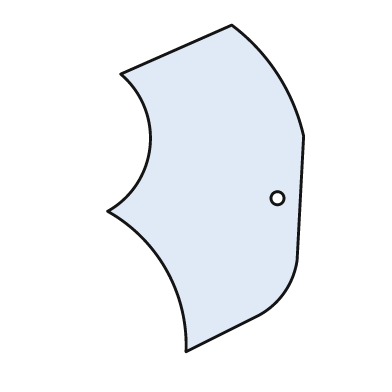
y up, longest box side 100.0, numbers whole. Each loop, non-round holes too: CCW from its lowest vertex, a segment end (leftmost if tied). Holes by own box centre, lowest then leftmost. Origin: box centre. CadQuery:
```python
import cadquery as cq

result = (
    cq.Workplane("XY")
    .moveTo(-6.0, -50.0)
    .lineTo(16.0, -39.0)
    .threePointArc((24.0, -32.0), (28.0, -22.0))
    .lineTo(30.0, 16.0)
    .threePointArc((22.0, 35.0), (8.0, 50.0))
    .lineTo(-26.0, 35.0)
    .threePointArc((-17.0, 13.0), (-30.0, -7.0))
    .threePointArc((-12.0, -25.0), (-6.0, -50.0))
    .close()
    .moveTo(22.0, -3.0)
    .circle(2.0)
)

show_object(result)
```